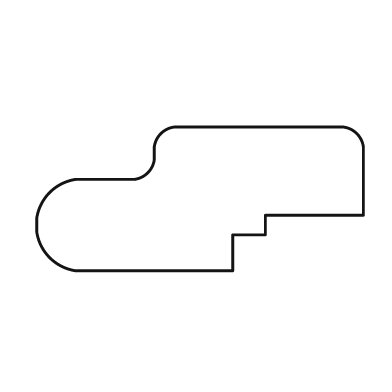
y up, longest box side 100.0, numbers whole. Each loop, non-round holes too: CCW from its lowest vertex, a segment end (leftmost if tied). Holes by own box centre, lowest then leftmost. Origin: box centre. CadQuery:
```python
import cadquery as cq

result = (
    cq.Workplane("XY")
    .moveTo(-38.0, -22.0)
    .lineTo(10.0, -22.0)
    .lineTo(10.0, -11.0)
    .lineTo(20.0, -11.0)
    .lineTo(20.0, -5.0)
    .lineTo(50.0, -5.0)
    .lineTo(50.0, 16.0)
    .threePointArc((48.0, 20.0), (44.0, 22.0))
    .lineTo(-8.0, 22.0)
    .threePointArc((-12.0, 20.0), (-14.0, 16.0))
    .lineTo(-14.0, 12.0)
    .threePointArc((-16.0, 8.0), (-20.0, 6.0))
    .lineTo(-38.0, 6.0)
    .threePointArc((-46.0, 2.0), (-50.0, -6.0))
    .lineTo(-50.0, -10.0)
    .threePointArc((-46.0, -18.0), (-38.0, -22.0))
    .close()
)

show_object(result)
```